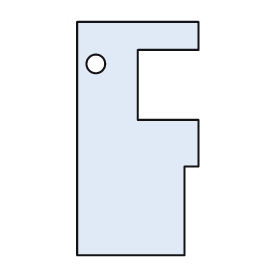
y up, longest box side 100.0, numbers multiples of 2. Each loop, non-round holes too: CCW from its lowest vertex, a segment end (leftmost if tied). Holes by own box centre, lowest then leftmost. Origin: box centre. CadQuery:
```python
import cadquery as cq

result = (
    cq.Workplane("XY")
    .moveTo(-26.0, -50.0)
    .lineTo(20.0, -50.0)
    .lineTo(20.0, -12.0)
    .lineTo(26.0, -12.0)
    .lineTo(26.0, 8.0)
    .lineTo(0.0, 8.0)
    .lineTo(0.0, 38.0)
    .lineTo(26.0, 38.0)
    .lineTo(26.0, 50.0)
    .lineTo(-26.0, 50.0)
    .close()
    .moveTo(-18.0, 32.0)
    .circle(4.0)
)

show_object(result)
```